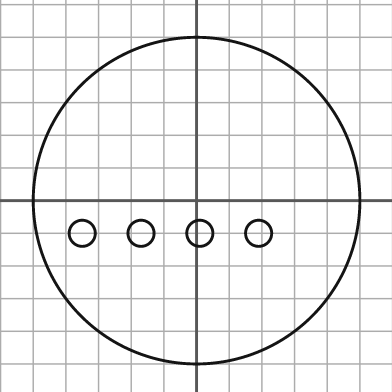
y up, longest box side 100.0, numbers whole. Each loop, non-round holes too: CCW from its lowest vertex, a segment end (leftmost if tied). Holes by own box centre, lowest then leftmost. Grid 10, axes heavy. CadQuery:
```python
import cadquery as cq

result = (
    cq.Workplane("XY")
    .moveTo(0.0, 0.0)
    .circle(50.0)
    .moveTo(-35.0, -10.0)
    .circle(4.0)
    .moveTo(-17.0, -10.0)
    .circle(4.0)
    .moveTo(1.0, -10.0)
    .circle(4.0)
    .moveTo(19.0, -10.0)
    .circle(4.0)
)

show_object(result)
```